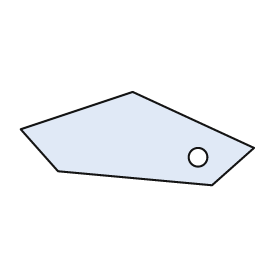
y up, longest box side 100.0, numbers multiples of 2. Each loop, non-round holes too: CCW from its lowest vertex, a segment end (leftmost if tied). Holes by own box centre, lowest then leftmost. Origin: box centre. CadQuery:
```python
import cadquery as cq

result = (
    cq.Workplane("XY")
    .moveTo(32.0, -20.0)
    .lineTo(50.0, -4.0)
    .lineTo(-2.0, 20.0)
    .lineTo(-50.0, 4.0)
    .lineTo(-34.0, -14.0)
    .close()
    .moveTo(26.0, -8.0)
    .circle(4.0)
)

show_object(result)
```